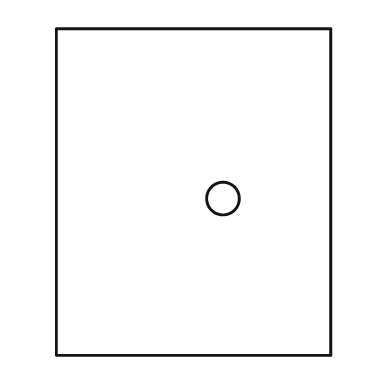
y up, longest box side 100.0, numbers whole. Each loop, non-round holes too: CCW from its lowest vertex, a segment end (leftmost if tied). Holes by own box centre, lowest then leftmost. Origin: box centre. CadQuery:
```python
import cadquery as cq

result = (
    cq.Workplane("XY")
    .moveTo(-42.0, -50.0)
    .lineTo(42.0, -50.0)
    .lineTo(42.0, 50.0)
    .lineTo(-42.0, 50.0)
    .close()
    .moveTo(9.0, -2.0)
    .circle(5.0)
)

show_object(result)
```